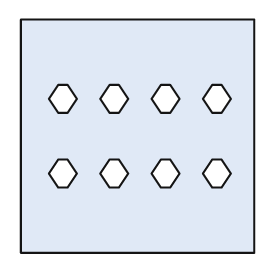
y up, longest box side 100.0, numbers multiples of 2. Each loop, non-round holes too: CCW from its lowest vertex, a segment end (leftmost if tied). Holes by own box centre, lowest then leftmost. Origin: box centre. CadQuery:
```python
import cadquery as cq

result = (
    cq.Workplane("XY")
    .moveTo(-50.0, -50.0)
    .lineTo(50.0, -50.0)
    .lineTo(50.0, 50.0)
    .lineTo(-50.0, 50.0)
    .close()
    .moveTo(-34.0, -22.0)
    .lineTo(-30.0, -22.0)
    .lineTo(-26.0, -16.0)
    .lineTo(-30.0, -10.0)
    .lineTo(-34.0, -10.0)
    .lineTo(-38.0, -16.0)
    .close()
    .moveTo(-12.0, -22.0)
    .lineTo(-8.0, -22.0)
    .lineTo(-4.0, -16.0)
    .lineTo(-8.0, -10.0)
    .lineTo(-12.0, -10.0)
    .lineTo(-16.0, -16.0)
    .close()
    .moveTo(10.0, -22.0)
    .lineTo(14.0, -22.0)
    .lineTo(18.0, -16.0)
    .lineTo(14.0, -10.0)
    .lineTo(10.0, -10.0)
    .lineTo(6.0, -16.0)
    .close()
    .moveTo(32.0, -22.0)
    .lineTo(36.0, -22.0)
    .lineTo(40.0, -16.0)
    .lineTo(36.0, -10.0)
    .lineTo(32.0, -10.0)
    .lineTo(28.0, -16.0)
    .close()
    .moveTo(-34.0, 10.0)
    .lineTo(-30.0, 10.0)
    .lineTo(-26.0, 16.0)
    .lineTo(-30.0, 22.0)
    .lineTo(-34.0, 22.0)
    .lineTo(-38.0, 16.0)
    .close()
    .moveTo(-12.0, 10.0)
    .lineTo(-8.0, 10.0)
    .lineTo(-4.0, 16.0)
    .lineTo(-8.0, 22.0)
    .lineTo(-12.0, 22.0)
    .lineTo(-16.0, 16.0)
    .close()
    .moveTo(10.0, 10.0)
    .lineTo(14.0, 10.0)
    .lineTo(18.0, 16.0)
    .lineTo(14.0, 22.0)
    .lineTo(10.0, 22.0)
    .lineTo(6.0, 16.0)
    .close()
    .moveTo(32.0, 10.0)
    .lineTo(36.0, 10.0)
    .lineTo(40.0, 16.0)
    .lineTo(36.0, 22.0)
    .lineTo(32.0, 22.0)
    .lineTo(28.0, 16.0)
    .close()
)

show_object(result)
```